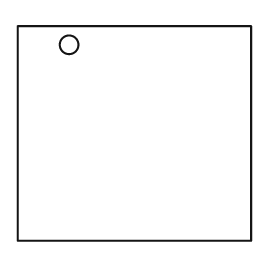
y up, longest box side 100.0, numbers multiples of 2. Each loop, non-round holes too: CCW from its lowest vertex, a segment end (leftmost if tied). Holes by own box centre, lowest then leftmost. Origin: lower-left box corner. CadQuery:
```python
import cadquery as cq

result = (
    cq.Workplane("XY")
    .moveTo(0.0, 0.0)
    .lineTo(100.0, 0.0)
    .lineTo(100.0, 92.0)
    .lineTo(0.0, 92.0)
    .close()
    .moveTo(22.0, 84.0)
    .circle(4.0)
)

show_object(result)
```